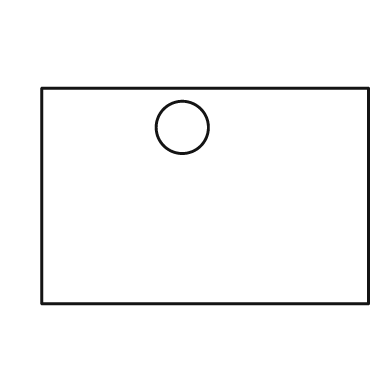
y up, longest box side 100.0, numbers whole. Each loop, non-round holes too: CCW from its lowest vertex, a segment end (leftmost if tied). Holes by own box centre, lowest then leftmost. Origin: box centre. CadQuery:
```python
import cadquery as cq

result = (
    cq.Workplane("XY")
    .moveTo(-50.0, -33.0)
    .lineTo(50.0, -33.0)
    .lineTo(50.0, 33.0)
    .lineTo(-50.0, 33.0)
    .close()
    .moveTo(-7.0, 21.0)
    .circle(8.0)
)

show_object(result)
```